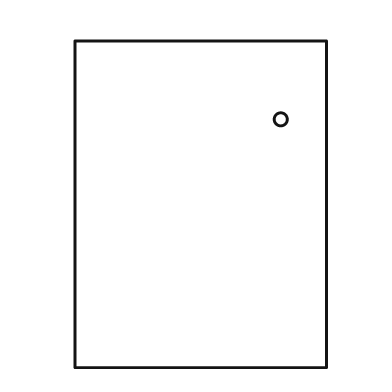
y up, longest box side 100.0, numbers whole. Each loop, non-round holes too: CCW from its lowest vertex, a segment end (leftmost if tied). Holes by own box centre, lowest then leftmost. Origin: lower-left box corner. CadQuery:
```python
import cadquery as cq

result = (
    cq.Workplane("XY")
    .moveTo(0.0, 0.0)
    .lineTo(77.0, 0.0)
    .lineTo(77.0, 100.0)
    .lineTo(0.0, 100.0)
    .close()
    .moveTo(63.0, 76.0)
    .circle(2.0)
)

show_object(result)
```